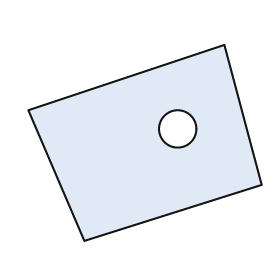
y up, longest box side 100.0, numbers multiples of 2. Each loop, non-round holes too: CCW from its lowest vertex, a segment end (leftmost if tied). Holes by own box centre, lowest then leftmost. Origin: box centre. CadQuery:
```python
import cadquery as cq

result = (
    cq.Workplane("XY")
    .moveTo(-26.0, -42.0)
    .lineTo(50.0, -18.0)
    .lineTo(34.0, 42.0)
    .lineTo(-50.0, 14.0)
    .close()
    .moveTo(14.0, 6.0)
    .circle(8.0)
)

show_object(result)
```